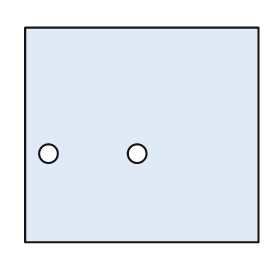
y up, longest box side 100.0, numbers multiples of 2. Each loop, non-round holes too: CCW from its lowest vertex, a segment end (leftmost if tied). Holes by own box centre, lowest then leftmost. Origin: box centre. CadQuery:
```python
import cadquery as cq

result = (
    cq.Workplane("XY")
    .moveTo(-50.0, -46.0)
    .lineTo(50.0, -46.0)
    .lineTo(50.0, 46.0)
    .lineTo(-50.0, 46.0)
    .close()
    .moveTo(-40.0, -8.0)
    .circle(4.0)
    .moveTo(-2.0, -8.0)
    .circle(4.0)
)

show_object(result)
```